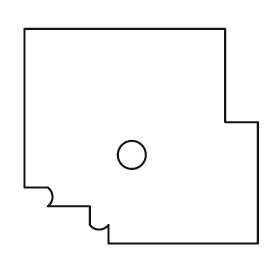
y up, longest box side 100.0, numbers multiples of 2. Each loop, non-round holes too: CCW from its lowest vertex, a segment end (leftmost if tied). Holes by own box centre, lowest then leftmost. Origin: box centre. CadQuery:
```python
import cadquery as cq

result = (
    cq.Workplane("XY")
    .moveTo(-14.0, -46.0)
    .lineTo(50.0, -46.0)
    .lineTo(50.0, 6.0)
    .lineTo(36.0, 6.0)
    .lineTo(36.0, 46.0)
    .lineTo(-50.0, 46.0)
    .lineTo(-50.0, -22.0)
    .lineTo(-40.0, -22.0)
    .threePointArc((-38.0, -26.0), (-40.0, -30.0))
    .lineTo(-22.0, -30.0)
    .lineTo(-22.0, -38.0)
    .threePointArc((-18.0, -40.0), (-14.0, -38.0))
    .close()
    .moveTo(-4.0, -8.0)
    .circle(6.0)
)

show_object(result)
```